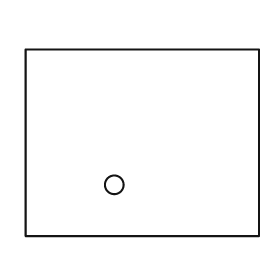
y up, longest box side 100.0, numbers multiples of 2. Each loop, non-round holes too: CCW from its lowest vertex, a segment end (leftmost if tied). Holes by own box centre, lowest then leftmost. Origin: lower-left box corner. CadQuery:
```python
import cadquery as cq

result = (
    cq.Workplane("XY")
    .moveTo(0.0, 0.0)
    .lineTo(100.0, 0.0)
    .lineTo(100.0, 80.0)
    .lineTo(0.0, 80.0)
    .close()
    .moveTo(38.0, 22.0)
    .circle(4.0)
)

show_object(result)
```